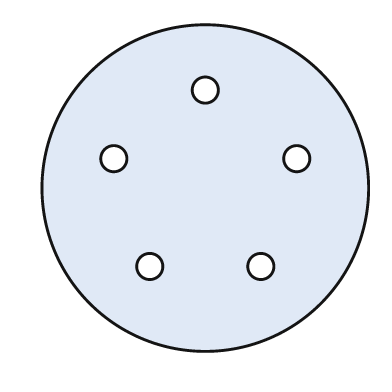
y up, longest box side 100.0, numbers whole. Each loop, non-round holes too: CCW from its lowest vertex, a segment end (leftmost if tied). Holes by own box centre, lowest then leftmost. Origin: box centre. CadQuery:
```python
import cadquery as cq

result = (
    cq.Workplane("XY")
    .moveTo(0.0, 0.0)
    .circle(50.0)
    .moveTo(-17.0, -24.0)
    .circle(4.0)
    .moveTo(17.0, -24.0)
    .circle(4.0)
    .moveTo(-28.0, 9.0)
    .circle(4.0)
    .moveTo(28.0, 9.0)
    .circle(4.0)
    .moveTo(0.0, 30.0)
    .circle(4.0)
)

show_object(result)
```